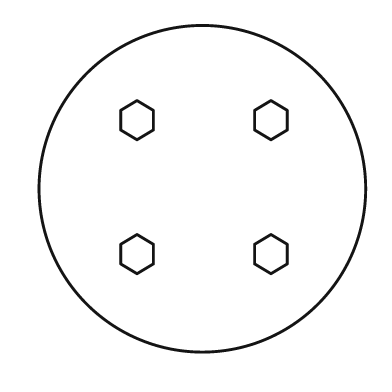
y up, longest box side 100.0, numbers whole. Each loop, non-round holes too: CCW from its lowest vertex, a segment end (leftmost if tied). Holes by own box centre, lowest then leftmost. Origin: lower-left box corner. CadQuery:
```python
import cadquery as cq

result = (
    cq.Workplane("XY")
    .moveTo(50.0, 50.0)
    .circle(50.0)
    .moveTo(30.0, 24.0)
    .lineTo(35.0, 27.0)
    .lineTo(35.0, 33.0)
    .lineTo(30.0, 36.0)
    .lineTo(25.0, 33.0)
    .lineTo(25.0, 27.0)
    .close()
    .moveTo(71.0, 24.0)
    .lineTo(76.0, 27.0)
    .lineTo(76.0, 33.0)
    .lineTo(71.0, 36.0)
    .lineTo(66.0, 33.0)
    .lineTo(66.0, 27.0)
    .close()
    .moveTo(30.0, 65.0)
    .lineTo(35.0, 68.0)
    .lineTo(35.0, 74.0)
    .lineTo(30.0, 77.0)
    .lineTo(25.0, 74.0)
    .lineTo(25.0, 68.0)
    .close()
    .moveTo(71.0, 65.0)
    .lineTo(76.0, 68.0)
    .lineTo(76.0, 74.0)
    .lineTo(71.0, 77.0)
    .lineTo(66.0, 74.0)
    .lineTo(66.0, 68.0)
    .close()
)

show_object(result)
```